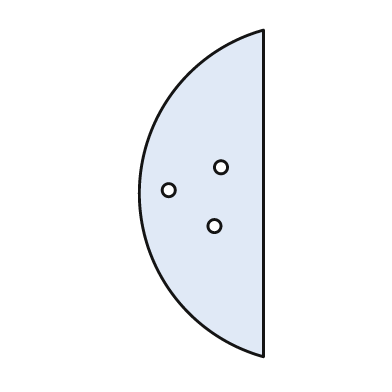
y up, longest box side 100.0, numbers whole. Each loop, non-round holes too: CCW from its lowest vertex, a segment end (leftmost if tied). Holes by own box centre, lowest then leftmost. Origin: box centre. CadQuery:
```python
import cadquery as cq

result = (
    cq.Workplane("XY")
    .moveTo(19.0, -50.0)
    .lineTo(19.0, 50.0)
    .threePointArc((-19.0, 0.0), (19.0, -50.0))
    .close()
    .moveTo(4.0, -10.0)
    .circle(2.0)
    .moveTo(-10.0, 1.0)
    .circle(2.0)
    .moveTo(6.0, 8.0)
    .circle(2.0)
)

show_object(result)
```